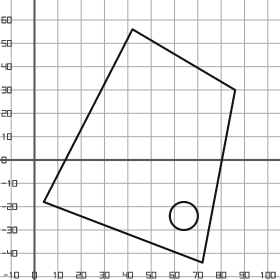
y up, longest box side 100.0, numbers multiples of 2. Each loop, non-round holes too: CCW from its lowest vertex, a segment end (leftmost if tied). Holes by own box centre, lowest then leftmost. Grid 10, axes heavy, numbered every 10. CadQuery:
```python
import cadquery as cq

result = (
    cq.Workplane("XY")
    .moveTo(72.0, -44.0)
    .lineTo(86.0, 30.0)
    .lineTo(42.0, 56.0)
    .lineTo(4.0, -18.0)
    .close()
    .moveTo(64.0, -24.0)
    .circle(6.0)
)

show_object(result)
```